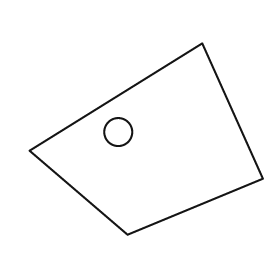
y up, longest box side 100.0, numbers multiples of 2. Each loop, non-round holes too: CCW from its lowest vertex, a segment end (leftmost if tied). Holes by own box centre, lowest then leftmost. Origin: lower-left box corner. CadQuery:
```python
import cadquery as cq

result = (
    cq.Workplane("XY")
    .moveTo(42.0, 0.0)
    .lineTo(100.0, 24.0)
    .lineTo(74.0, 82.0)
    .lineTo(0.0, 36.0)
    .close()
    .moveTo(38.0, 44.0)
    .circle(6.0)
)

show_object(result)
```